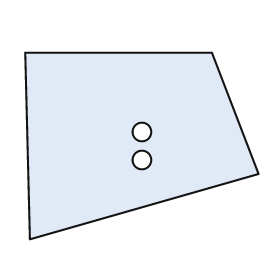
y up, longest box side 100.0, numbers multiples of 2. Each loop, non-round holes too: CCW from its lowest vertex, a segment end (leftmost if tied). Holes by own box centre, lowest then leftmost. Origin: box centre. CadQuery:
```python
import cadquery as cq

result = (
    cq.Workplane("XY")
    .moveTo(-48.0, -40.0)
    .lineTo(50.0, -12.0)
    .lineTo(30.0, 40.0)
    .lineTo(-50.0, 40.0)
    .close()
    .moveTo(0.0, -6.0)
    .circle(4.0)
    .moveTo(0.0, 6.0)
    .circle(4.0)
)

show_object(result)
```